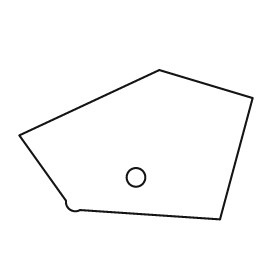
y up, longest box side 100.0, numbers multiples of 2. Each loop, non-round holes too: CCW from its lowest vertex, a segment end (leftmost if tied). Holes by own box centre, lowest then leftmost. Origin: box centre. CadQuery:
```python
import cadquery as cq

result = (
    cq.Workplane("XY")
    .moveTo(36.0, -32.0)
    .lineTo(50.0, 20.0)
    .lineTo(10.0, 32.0)
    .lineTo(-50.0, 4.0)
    .lineTo(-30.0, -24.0)
    .threePointArc((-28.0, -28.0), (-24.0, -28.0))
    .close()
    .moveTo(0.0, -14.0)
    .circle(4.0)
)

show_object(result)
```